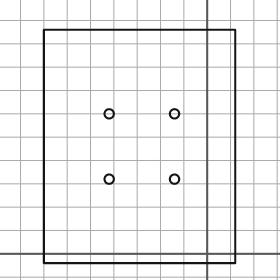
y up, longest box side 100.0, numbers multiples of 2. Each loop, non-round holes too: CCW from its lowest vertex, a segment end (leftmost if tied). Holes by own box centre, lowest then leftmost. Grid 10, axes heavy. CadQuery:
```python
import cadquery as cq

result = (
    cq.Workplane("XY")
    .moveTo(-70.0, -4.0)
    .lineTo(12.0, -4.0)
    .lineTo(12.0, 96.0)
    .lineTo(-70.0, 96.0)
    .close()
    .moveTo(-42.0, 32.0)
    .circle(2.0)
    .moveTo(-14.0, 32.0)
    .circle(2.0)
    .moveTo(-42.0, 60.0)
    .circle(2.0)
    .moveTo(-14.0, 60.0)
    .circle(2.0)
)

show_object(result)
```